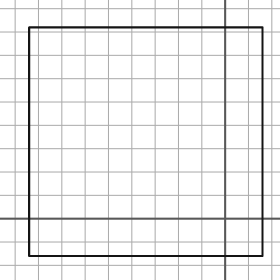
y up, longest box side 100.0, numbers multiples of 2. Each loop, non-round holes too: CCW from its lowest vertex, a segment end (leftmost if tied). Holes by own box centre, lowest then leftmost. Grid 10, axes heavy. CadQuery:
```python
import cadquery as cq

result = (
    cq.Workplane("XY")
    .moveTo(-84.0, -16.0)
    .lineTo(16.0, -16.0)
    .lineTo(16.0, 82.0)
    .lineTo(-84.0, 82.0)
    .close()
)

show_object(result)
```